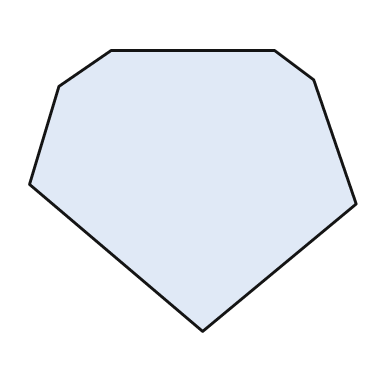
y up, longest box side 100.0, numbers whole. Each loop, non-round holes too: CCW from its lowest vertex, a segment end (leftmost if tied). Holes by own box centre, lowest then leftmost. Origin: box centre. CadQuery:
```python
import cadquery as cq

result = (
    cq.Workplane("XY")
    .moveTo(3.0, -43.0)
    .lineTo(50.0, -4.0)
    .lineTo(37.0, 34.0)
    .lineTo(25.0, 43.0)
    .lineTo(-25.0, 43.0)
    .lineTo(-41.0, 32.0)
    .lineTo(-50.0, 2.0)
    .close()
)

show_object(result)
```